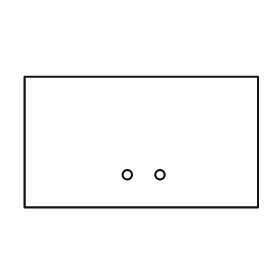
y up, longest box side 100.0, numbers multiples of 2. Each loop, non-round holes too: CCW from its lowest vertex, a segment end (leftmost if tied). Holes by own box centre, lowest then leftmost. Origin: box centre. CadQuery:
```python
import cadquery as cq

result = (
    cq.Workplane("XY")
    .moveTo(-50.0, -28.0)
    .lineTo(50.0, -28.0)
    .lineTo(50.0, 28.0)
    .lineTo(-50.0, 28.0)
    .close()
    .moveTo(-6.0, -14.0)
    .circle(2.0)
    .moveTo(8.0, -14.0)
    .circle(2.0)
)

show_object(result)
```